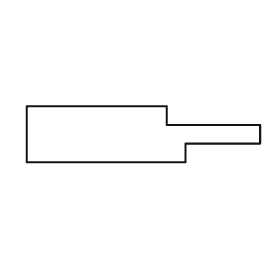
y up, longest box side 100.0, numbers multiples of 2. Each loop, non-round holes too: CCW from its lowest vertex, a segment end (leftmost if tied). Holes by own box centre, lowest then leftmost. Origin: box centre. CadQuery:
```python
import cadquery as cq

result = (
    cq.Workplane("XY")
    .moveTo(-50.0, -12.0)
    .lineTo(18.0, -12.0)
    .lineTo(18.0, -4.0)
    .lineTo(50.0, -4.0)
    .lineTo(50.0, 4.0)
    .lineTo(10.0, 4.0)
    .lineTo(10.0, 12.0)
    .lineTo(-50.0, 12.0)
    .close()
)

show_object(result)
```